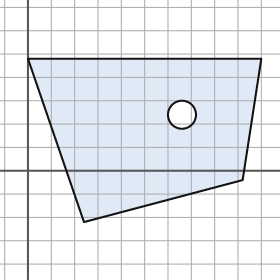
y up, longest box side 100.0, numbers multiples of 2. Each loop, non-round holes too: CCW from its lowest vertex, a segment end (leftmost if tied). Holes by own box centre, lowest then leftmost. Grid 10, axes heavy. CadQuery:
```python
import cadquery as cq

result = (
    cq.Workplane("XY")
    .moveTo(24.0, -22.0)
    .lineTo(92.0, -4.0)
    .lineTo(100.0, 48.0)
    .lineTo(0.0, 48.0)
    .close()
    .moveTo(66.0, 24.0)
    .circle(6.0)
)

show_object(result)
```